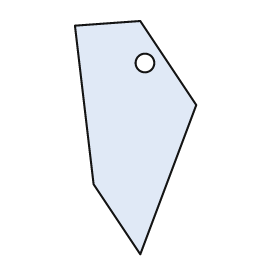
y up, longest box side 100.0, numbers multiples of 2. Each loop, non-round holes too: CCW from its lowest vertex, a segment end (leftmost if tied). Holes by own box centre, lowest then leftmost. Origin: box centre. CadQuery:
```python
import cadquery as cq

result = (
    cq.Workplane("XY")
    .moveTo(2.0, -50.0)
    .lineTo(26.0, 14.0)
    .lineTo(2.0, 50.0)
    .lineTo(-26.0, 48.0)
    .lineTo(-18.0, -20.0)
    .close()
    .moveTo(4.0, 32.0)
    .circle(4.0)
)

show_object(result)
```